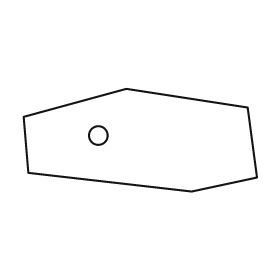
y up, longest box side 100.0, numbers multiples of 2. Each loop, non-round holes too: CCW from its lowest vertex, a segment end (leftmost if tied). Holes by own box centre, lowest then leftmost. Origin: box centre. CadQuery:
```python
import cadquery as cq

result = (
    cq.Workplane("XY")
    .moveTo(22.0, -22.0)
    .lineTo(50.0, -16.0)
    .lineTo(46.0, 14.0)
    .lineTo(-6.0, 22.0)
    .lineTo(-50.0, 10.0)
    .lineTo(-48.0, -14.0)
    .close()
    .moveTo(-18.0, 2.0)
    .circle(4.0)
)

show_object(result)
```